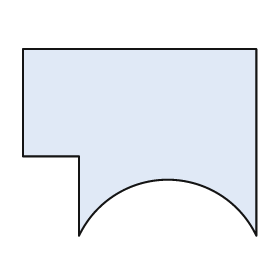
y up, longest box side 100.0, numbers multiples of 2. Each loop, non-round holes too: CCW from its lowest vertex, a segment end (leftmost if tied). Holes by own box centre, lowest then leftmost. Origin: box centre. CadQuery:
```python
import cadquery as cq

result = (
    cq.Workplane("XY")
    .moveTo(-26.0, -40.0)
    .threePointArc((12.0, -16.0), (50.0, -40.0))
    .lineTo(50.0, 40.0)
    .lineTo(-50.0, 40.0)
    .lineTo(-50.0, -6.0)
    .lineTo(-26.0, -6.0)
    .close()
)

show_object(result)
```